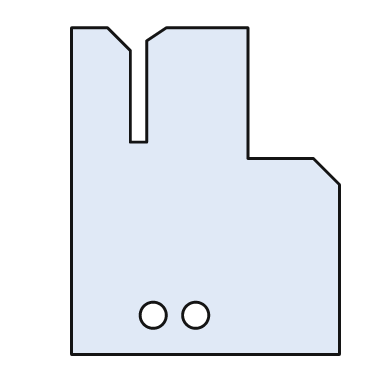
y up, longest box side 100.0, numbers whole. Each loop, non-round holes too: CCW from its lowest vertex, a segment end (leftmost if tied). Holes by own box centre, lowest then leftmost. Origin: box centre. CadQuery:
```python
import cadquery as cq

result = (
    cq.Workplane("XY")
    .moveTo(-41.0, -50.0)
    .lineTo(41.0, -50.0)
    .lineTo(41.0, 2.0)
    .lineTo(33.0, 10.0)
    .lineTo(13.0, 10.0)
    .lineTo(13.0, 50.0)
    .lineTo(-12.0, 50.0)
    .lineTo(-18.0, 46.0)
    .lineTo(-18.0, 15.0)
    .lineTo(-23.0, 15.0)
    .lineTo(-23.0, 43.0)
    .lineTo(-30.0, 50.0)
    .lineTo(-41.0, 50.0)
    .close()
    .moveTo(-16.0, -38.0)
    .circle(4.0)
    .moveTo(-3.0, -38.0)
    .circle(4.0)
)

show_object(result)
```